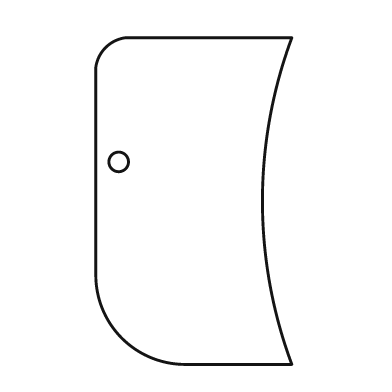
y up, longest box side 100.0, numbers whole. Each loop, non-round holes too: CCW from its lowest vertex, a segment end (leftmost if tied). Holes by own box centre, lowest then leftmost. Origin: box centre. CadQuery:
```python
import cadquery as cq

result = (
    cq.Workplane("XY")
    .moveTo(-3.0, -50.0)
    .lineTo(30.0, -50.0)
    .threePointArc((21.0, 0.0), (30.0, 50.0))
    .lineTo(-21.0, 50.0)
    .threePointArc((-27.0, 47.0), (-30.0, 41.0))
    .lineTo(-30.0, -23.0)
    .threePointArc((-22.0, -42.0), (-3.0, -50.0))
    .close()
    .moveTo(-23.0, 12.0)
    .circle(3.0)
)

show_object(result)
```